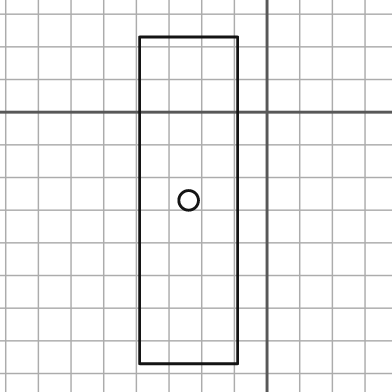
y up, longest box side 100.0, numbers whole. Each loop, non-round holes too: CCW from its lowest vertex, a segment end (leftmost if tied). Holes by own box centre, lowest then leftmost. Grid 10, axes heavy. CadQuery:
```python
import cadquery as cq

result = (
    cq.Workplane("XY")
    .moveTo(-39.0, -77.0)
    .lineTo(-9.0, -77.0)
    .lineTo(-9.0, 23.0)
    .lineTo(-39.0, 23.0)
    .close()
    .moveTo(-24.0, -27.0)
    .circle(3.0)
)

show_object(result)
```